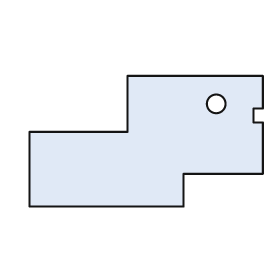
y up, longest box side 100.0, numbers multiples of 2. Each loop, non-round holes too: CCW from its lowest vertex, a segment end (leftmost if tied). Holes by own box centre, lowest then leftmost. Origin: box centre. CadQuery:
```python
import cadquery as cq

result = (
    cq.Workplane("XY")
    .moveTo(-50.0, -28.0)
    .lineTo(16.0, -28.0)
    .lineTo(16.0, -14.0)
    .lineTo(50.0, -14.0)
    .lineTo(50.0, 8.0)
    .lineTo(46.0, 8.0)
    .lineTo(46.0, 14.0)
    .lineTo(50.0, 14.0)
    .lineTo(50.0, 28.0)
    .lineTo(-8.0, 28.0)
    .lineTo(-8.0, 4.0)
    .lineTo(-50.0, 4.0)
    .close()
    .moveTo(30.0, 16.0)
    .circle(4.0)
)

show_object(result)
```